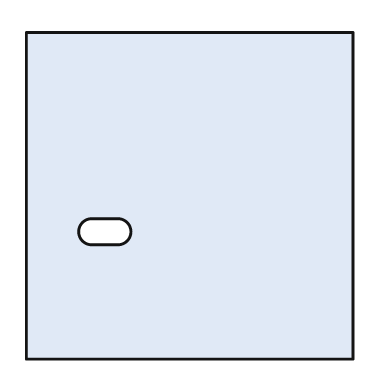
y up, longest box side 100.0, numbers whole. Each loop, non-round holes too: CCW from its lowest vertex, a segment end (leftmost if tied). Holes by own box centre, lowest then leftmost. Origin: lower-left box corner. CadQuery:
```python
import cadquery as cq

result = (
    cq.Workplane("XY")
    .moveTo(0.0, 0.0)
    .lineTo(100.0, 0.0)
    .lineTo(100.0, 100.0)
    .lineTo(0.0, 100.0)
    .close()
    .moveTo(20.0, 35.0)
    .lineTo(28.0, 35.0)
    .threePointArc((32.0, 39.0), (28.0, 43.0))
    .lineTo(20.0, 43.0)
    .threePointArc((16.0, 39.0), (20.0, 35.0))
    .close()
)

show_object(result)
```